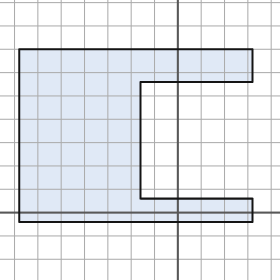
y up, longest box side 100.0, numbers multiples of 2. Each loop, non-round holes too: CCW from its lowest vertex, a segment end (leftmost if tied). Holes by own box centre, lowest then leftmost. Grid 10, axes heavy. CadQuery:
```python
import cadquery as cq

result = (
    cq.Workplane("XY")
    .moveTo(-68.0, -4.0)
    .lineTo(32.0, -4.0)
    .lineTo(32.0, 6.0)
    .lineTo(-16.0, 6.0)
    .lineTo(-16.0, 56.0)
    .lineTo(32.0, 56.0)
    .lineTo(32.0, 70.0)
    .lineTo(-68.0, 70.0)
    .close()
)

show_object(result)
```